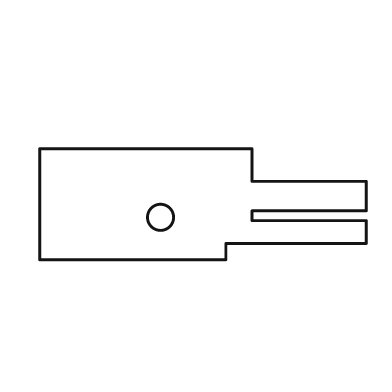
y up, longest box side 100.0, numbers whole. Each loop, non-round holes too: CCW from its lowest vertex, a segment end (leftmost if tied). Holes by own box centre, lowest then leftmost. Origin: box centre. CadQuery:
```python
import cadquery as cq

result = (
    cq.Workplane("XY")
    .moveTo(-50.0, -17.0)
    .lineTo(7.0, -17.0)
    .lineTo(7.0, -12.0)
    .lineTo(50.0, -12.0)
    .lineTo(50.0, -5.0)
    .lineTo(15.0, -5.0)
    .lineTo(15.0, -2.0)
    .lineTo(50.0, -2.0)
    .lineTo(50.0, 7.0)
    .lineTo(15.0, 7.0)
    .lineTo(15.0, 17.0)
    .lineTo(-50.0, 17.0)
    .close()
    .moveTo(-13.0, -4.0)
    .circle(4.0)
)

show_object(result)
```